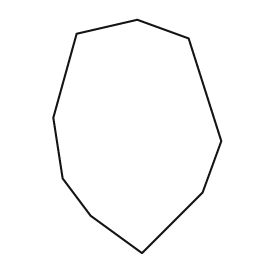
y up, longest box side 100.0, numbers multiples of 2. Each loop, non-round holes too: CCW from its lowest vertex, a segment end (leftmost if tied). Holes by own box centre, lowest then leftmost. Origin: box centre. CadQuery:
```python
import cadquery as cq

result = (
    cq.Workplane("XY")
    .moveTo(2.0, -50.0)
    .lineTo(28.0, -24.0)
    .lineTo(36.0, -2.0)
    .lineTo(22.0, 42.0)
    .lineTo(0.0, 50.0)
    .lineTo(-26.0, 44.0)
    .lineTo(-36.0, 8.0)
    .lineTo(-32.0, -18.0)
    .lineTo(-20.0, -34.0)
    .close()
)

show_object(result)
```